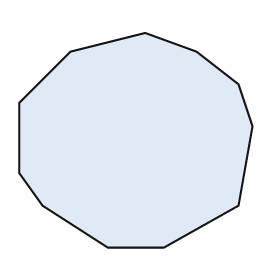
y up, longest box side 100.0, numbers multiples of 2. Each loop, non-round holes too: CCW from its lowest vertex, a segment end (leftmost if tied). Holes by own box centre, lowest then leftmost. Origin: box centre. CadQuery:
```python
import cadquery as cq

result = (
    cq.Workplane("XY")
    .moveTo(-12.0, -46.0)
    .lineTo(12.0, -46.0)
    .lineTo(44.0, -28.0)
    .lineTo(50.0, 6.0)
    .lineTo(44.0, 24.0)
    .lineTo(26.0, 38.0)
    .lineTo(4.0, 46.0)
    .lineTo(-28.0, 38.0)
    .lineTo(-50.0, 16.0)
    .lineTo(-50.0, -14.0)
    .lineTo(-40.0, -28.0)
    .close()
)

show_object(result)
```